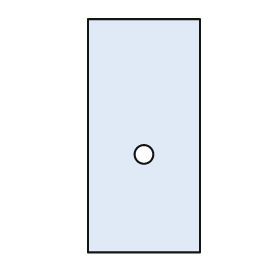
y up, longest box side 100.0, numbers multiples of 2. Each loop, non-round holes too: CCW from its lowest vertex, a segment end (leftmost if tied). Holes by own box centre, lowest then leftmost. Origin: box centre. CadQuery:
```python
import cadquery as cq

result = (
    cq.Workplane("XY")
    .moveTo(-24.0, -50.0)
    .lineTo(24.0, -50.0)
    .lineTo(24.0, 50.0)
    .lineTo(-24.0, 50.0)
    .close()
    .moveTo(0.0, -8.0)
    .circle(4.0)
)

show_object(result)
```